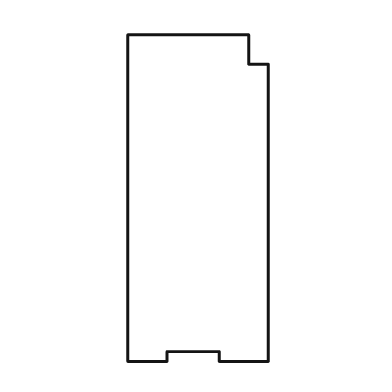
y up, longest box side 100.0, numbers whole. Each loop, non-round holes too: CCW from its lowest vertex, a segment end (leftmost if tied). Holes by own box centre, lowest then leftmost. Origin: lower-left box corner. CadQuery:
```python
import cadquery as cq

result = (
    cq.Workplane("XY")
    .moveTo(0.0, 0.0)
    .lineTo(12.0, 0.0)
    .lineTo(12.0, 3.0)
    .lineTo(28.0, 3.0)
    .lineTo(28.0, 0.0)
    .lineTo(43.0, 0.0)
    .lineTo(43.0, 91.0)
    .lineTo(37.0, 91.0)
    .lineTo(37.0, 100.0)
    .lineTo(0.0, 100.0)
    .close()
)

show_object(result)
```